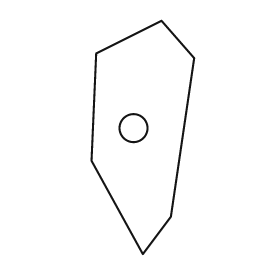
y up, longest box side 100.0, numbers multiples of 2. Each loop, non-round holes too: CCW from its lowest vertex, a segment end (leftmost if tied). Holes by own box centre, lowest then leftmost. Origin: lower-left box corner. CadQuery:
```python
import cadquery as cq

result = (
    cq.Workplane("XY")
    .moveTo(22.0, 0.0)
    .lineTo(34.0, 16.0)
    .lineTo(44.0, 84.0)
    .lineTo(30.0, 100.0)
    .lineTo(2.0, 86.0)
    .lineTo(0.0, 40.0)
    .close()
    .moveTo(18.0, 54.0)
    .circle(6.0)
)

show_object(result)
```